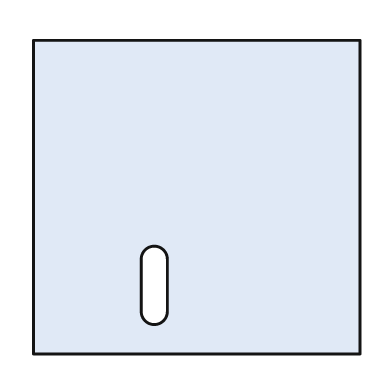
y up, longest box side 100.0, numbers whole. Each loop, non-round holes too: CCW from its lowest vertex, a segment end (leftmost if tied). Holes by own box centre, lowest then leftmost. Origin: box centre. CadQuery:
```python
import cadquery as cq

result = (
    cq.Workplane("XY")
    .moveTo(-50.0, -48.0)
    .lineTo(50.0, -48.0)
    .lineTo(50.0, 48.0)
    .lineTo(-50.0, 48.0)
    .close()
    .moveTo(-17.0, -35.0)
    .threePointArc((-13.0, -39.0), (-9.0, -35.0))
    .lineTo(-9.0, -19.0)
    .threePointArc((-13.0, -15.0), (-17.0, -19.0))
    .close()
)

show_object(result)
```